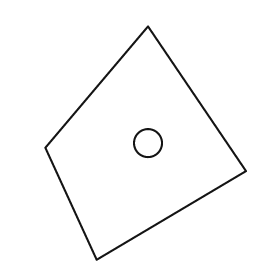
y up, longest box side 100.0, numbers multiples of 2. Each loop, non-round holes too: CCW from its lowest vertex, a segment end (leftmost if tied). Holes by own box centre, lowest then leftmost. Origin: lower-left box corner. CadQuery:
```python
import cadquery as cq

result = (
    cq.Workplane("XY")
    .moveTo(22.0, 0.0)
    .lineTo(86.0, 38.0)
    .lineTo(44.0, 100.0)
    .lineTo(0.0, 48.0)
    .close()
    .moveTo(44.0, 50.0)
    .circle(6.0)
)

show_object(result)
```